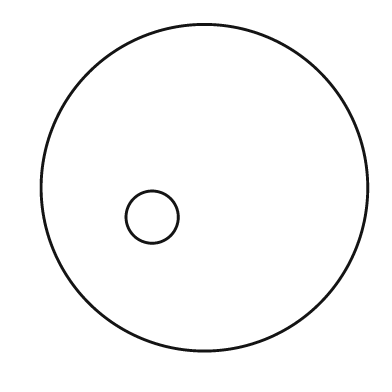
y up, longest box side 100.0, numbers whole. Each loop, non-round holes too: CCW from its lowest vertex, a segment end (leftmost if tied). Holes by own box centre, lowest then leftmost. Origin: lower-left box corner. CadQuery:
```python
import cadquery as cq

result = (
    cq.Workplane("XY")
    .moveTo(50.0, 50.0)
    .circle(50.0)
    .moveTo(34.0, 41.0)
    .circle(8.0)
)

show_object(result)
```